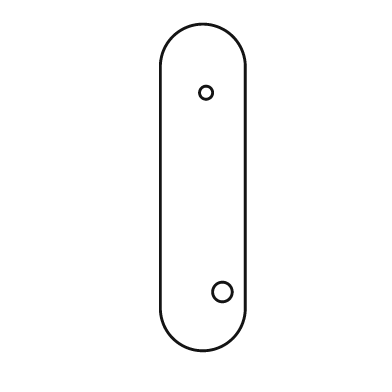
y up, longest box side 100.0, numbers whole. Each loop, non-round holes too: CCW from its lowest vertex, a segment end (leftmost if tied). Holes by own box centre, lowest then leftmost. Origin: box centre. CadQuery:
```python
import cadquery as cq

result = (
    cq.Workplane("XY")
    .moveTo(-13.0, -37.0)
    .threePointArc((0.0, -50.0), (13.0, -37.0))
    .lineTo(13.0, 37.0)
    .threePointArc((0.0, 50.0), (-13.0, 37.0))
    .close()
    .moveTo(6.0, -32.0)
    .circle(3.0)
    .moveTo(1.0, 29.0)
    .circle(2.0)
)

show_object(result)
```